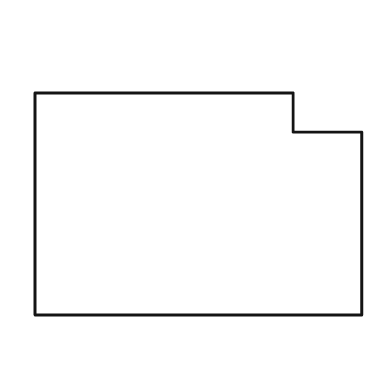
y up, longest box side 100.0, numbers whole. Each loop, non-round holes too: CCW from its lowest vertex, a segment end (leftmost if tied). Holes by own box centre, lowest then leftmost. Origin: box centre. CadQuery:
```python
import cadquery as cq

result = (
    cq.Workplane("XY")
    .moveTo(-50.0, -34.0)
    .lineTo(50.0, -34.0)
    .lineTo(50.0, 22.0)
    .lineTo(29.0, 22.0)
    .lineTo(29.0, 34.0)
    .lineTo(-50.0, 34.0)
    .close()
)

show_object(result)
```